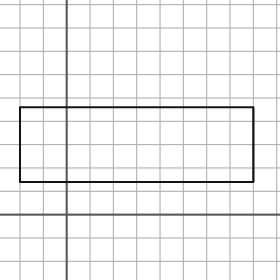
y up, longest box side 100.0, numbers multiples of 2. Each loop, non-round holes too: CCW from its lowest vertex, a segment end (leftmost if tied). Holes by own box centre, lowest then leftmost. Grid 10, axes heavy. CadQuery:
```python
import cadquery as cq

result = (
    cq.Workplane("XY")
    .moveTo(-20.0, 14.0)
    .lineTo(80.0, 14.0)
    .lineTo(80.0, 46.0)
    .lineTo(-20.0, 46.0)
    .close()
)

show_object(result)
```